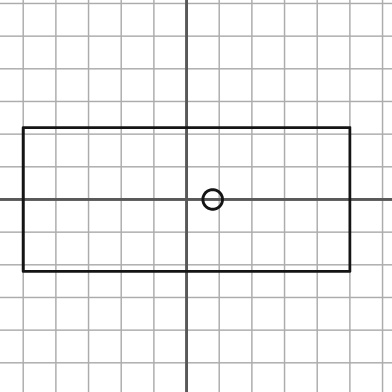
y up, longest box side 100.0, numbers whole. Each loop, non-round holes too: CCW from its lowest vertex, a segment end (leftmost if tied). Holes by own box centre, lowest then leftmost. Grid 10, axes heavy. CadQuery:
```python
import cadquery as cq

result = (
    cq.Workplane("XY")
    .moveTo(-50.0, -22.0)
    .lineTo(50.0, -22.0)
    .lineTo(50.0, 22.0)
    .lineTo(-50.0, 22.0)
    .close()
    .moveTo(8.0, 0.0)
    .circle(3.0)
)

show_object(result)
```